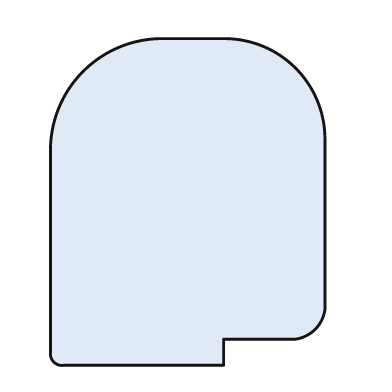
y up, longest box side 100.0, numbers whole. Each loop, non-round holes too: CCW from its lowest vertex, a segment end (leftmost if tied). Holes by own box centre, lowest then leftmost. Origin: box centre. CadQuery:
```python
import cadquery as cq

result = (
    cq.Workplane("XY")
    .moveTo(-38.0, -50.0)
    .lineTo(11.0, -50.0)
    .lineTo(11.0, -42.0)
    .lineTo(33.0, -42.0)
    .threePointArc((39.0, -39.0), (42.0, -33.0))
    .lineTo(42.0, 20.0)
    .threePointArc((33.0, 41.0), (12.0, 50.0))
    .lineTo(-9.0, 50.0)
    .threePointArc((-32.0, 40.0), (-42.0, 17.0))
    .lineTo(-42.0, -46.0)
    .threePointArc((-41.0, -49.0), (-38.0, -50.0))
    .close()
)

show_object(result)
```